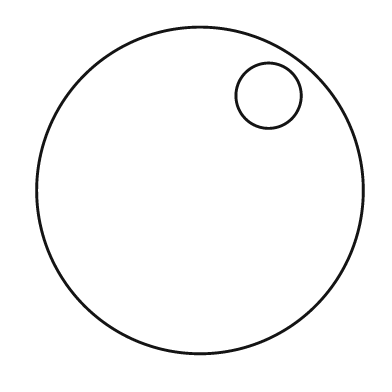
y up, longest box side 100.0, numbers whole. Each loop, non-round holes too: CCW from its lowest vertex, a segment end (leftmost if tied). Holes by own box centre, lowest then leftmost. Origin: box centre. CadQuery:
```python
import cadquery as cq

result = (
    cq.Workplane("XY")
    .moveTo(0.0, 0.0)
    .circle(50.0)
    .moveTo(21.0, 29.0)
    .circle(10.0)
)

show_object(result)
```